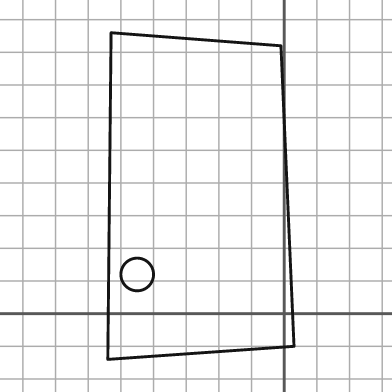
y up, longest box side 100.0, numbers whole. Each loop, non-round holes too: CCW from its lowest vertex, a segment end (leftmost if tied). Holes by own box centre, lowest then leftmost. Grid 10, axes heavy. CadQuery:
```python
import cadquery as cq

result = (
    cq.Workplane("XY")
    .moveTo(-54.0, -14.0)
    .lineTo(3.0, -10.0)
    .lineTo(-1.0, 82.0)
    .lineTo(-53.0, 86.0)
    .close()
    .moveTo(-45.0, 12.0)
    .circle(5.0)
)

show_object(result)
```